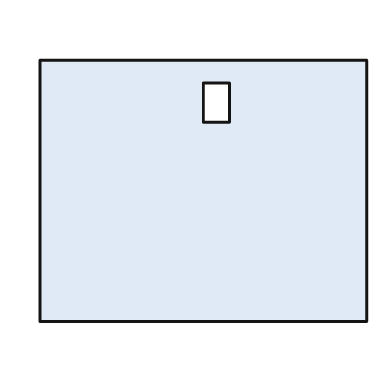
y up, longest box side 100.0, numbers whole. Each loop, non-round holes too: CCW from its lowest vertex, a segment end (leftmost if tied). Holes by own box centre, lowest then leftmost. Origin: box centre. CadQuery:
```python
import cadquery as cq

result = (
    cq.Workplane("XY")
    .moveTo(-50.0, -40.0)
    .lineTo(50.0, -40.0)
    .lineTo(50.0, 40.0)
    .lineTo(-50.0, 40.0)
    .close()
    .moveTo(0.0, 21.0)
    .lineTo(8.0, 21.0)
    .lineTo(8.0, 33.0)
    .lineTo(0.0, 33.0)
    .close()
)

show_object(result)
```